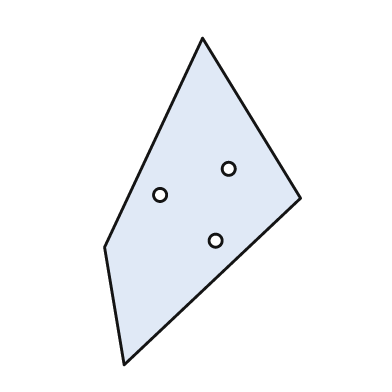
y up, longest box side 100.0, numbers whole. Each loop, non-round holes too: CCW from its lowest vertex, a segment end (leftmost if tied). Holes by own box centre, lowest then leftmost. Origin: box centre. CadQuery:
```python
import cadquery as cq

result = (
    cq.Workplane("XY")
    .moveTo(-24.0, -50.0)
    .lineTo(30.0, 1.0)
    .lineTo(0.0, 50.0)
    .lineTo(-30.0, -14.0)
    .close()
    .moveTo(4.0, -12.0)
    .circle(2.0)
    .moveTo(-13.0, 2.0)
    .circle(2.0)
    .moveTo(8.0, 10.0)
    .circle(2.0)
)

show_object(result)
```